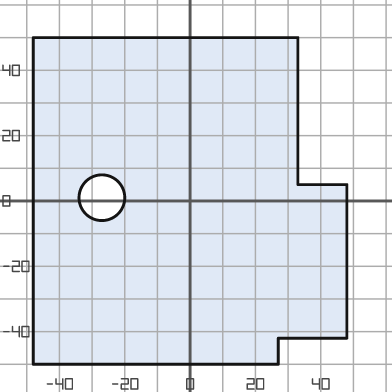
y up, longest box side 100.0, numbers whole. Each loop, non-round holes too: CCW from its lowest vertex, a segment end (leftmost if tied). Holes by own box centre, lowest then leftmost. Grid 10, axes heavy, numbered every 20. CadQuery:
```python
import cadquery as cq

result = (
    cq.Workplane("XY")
    .moveTo(-48.0, -50.0)
    .lineTo(27.0, -50.0)
    .lineTo(27.0, -42.0)
    .lineTo(48.0, -42.0)
    .lineTo(48.0, 5.0)
    .lineTo(33.0, 5.0)
    .lineTo(33.0, 50.0)
    .lineTo(-48.0, 50.0)
    .close()
    .moveTo(-27.0, 1.0)
    .circle(7.0)
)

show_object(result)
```